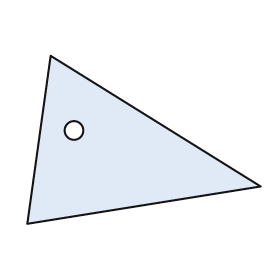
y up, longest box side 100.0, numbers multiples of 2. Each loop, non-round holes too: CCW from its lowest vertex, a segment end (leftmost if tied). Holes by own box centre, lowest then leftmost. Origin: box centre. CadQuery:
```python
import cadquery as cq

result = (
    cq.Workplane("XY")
    .moveTo(-50.0, -36.0)
    .lineTo(50.0, -20.0)
    .lineTo(-40.0, 36.0)
    .close()
    .moveTo(-30.0, 4.0)
    .circle(4.0)
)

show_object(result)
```